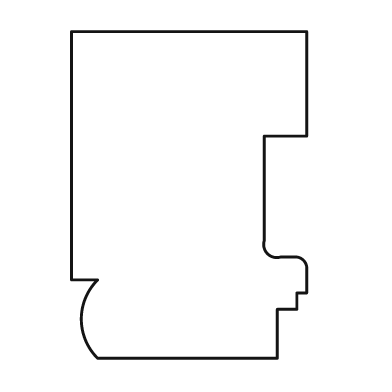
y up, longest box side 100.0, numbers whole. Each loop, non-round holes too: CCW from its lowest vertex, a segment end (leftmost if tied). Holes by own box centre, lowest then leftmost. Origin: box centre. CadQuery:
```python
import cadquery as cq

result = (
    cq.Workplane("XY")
    .moveTo(-28.0, -50.0)
    .lineTo(27.0, -50.0)
    .lineTo(27.0, -35.0)
    .lineTo(33.0, -35.0)
    .lineTo(33.0, -30.0)
    .lineTo(36.0, -30.0)
    .lineTo(36.0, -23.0)
    .threePointArc((35.0, -20.0), (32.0, -19.0))
    .lineTo(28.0, -19.0)
    .threePointArc((24.0, -18.0), (23.0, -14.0))
    .lineTo(23.0, 18.0)
    .lineTo(36.0, 18.0)
    .lineTo(36.0, 50.0)
    .lineTo(-36.0, 50.0)
    .lineTo(-36.0, -26.0)
    .lineTo(-28.0, -26.0)
    .threePointArc((-33.0, -38.0), (-28.0, -50.0))
    .close()
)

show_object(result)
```